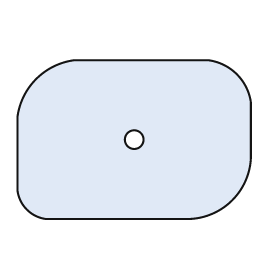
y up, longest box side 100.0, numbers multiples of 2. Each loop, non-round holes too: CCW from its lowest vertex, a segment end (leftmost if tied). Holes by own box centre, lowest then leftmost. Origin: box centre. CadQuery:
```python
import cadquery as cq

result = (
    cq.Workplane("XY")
    .moveTo(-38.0, -34.0)
    .lineTo(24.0, -34.0)
    .threePointArc((42.0, -26.0), (50.0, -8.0))
    .lineTo(50.0, 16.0)
    .threePointArc((44.0, 28.0), (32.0, 34.0))
    .lineTo(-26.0, 34.0)
    .threePointArc((-42.0, 26.0), (-50.0, 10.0))
    .lineTo(-50.0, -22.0)
    .threePointArc((-46.0, -30.0), (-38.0, -34.0))
    .close()
    .moveTo(0.0, 0.0)
    .circle(4.0)
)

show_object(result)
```